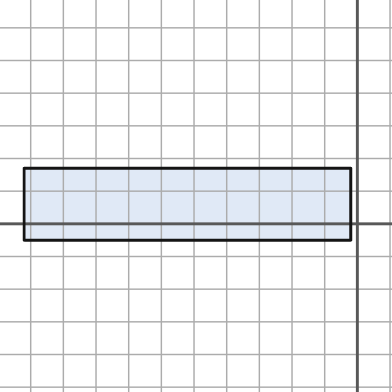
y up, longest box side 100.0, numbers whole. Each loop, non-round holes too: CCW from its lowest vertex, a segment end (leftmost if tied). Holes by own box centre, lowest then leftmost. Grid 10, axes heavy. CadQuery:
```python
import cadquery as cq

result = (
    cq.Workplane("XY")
    .moveTo(-102.0, -5.0)
    .lineTo(-2.0, -5.0)
    .lineTo(-2.0, 17.0)
    .lineTo(-102.0, 17.0)
    .close()
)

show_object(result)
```